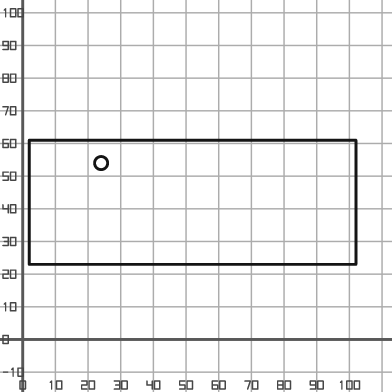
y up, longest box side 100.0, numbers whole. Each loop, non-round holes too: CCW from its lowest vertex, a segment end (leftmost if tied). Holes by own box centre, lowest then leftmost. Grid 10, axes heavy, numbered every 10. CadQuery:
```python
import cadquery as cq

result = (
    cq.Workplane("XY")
    .moveTo(2.0, 23.0)
    .lineTo(102.0, 23.0)
    .lineTo(102.0, 61.0)
    .lineTo(2.0, 61.0)
    .close()
    .moveTo(24.0, 54.0)
    .circle(2.0)
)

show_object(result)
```